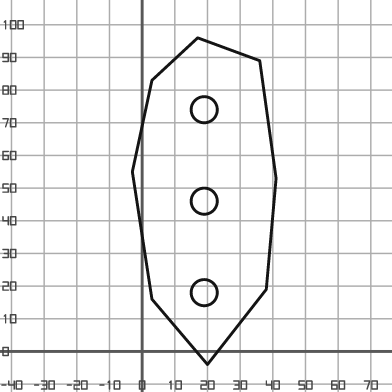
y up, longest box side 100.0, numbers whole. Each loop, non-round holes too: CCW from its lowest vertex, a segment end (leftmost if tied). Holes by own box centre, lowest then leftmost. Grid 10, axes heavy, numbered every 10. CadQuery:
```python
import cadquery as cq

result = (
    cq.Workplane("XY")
    .moveTo(20.0, -4.0)
    .lineTo(38.0, 19.0)
    .lineTo(41.0, 53.0)
    .lineTo(36.0, 89.0)
    .lineTo(17.0, 96.0)
    .lineTo(3.0, 83.0)
    .lineTo(-3.0, 55.0)
    .lineTo(3.0, 16.0)
    .close()
    .moveTo(19.0, 18.0)
    .circle(4.0)
    .moveTo(19.0, 46.0)
    .circle(4.0)
    .moveTo(19.0, 74.0)
    .circle(4.0)
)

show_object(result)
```